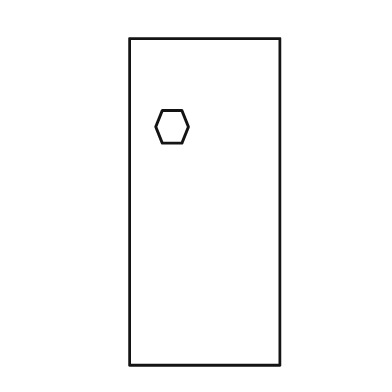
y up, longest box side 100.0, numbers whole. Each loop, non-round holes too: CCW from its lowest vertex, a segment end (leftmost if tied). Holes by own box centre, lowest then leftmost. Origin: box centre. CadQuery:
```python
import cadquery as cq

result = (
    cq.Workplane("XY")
    .moveTo(-23.0, -50.0)
    .lineTo(23.0, -50.0)
    .lineTo(23.0, 50.0)
    .lineTo(-23.0, 50.0)
    .close()
    .moveTo(-13.0, 18.0)
    .lineTo(-7.0, 18.0)
    .lineTo(-5.0, 23.0)
    .lineTo(-7.0, 28.0)
    .lineTo(-13.0, 28.0)
    .lineTo(-15.0, 23.0)
    .close()
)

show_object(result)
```